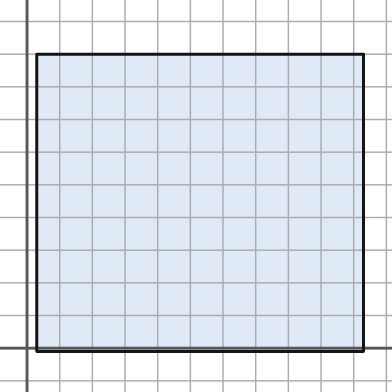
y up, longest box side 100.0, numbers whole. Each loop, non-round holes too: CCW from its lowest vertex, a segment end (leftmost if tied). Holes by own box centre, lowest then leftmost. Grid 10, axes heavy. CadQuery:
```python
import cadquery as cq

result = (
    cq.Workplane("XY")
    .moveTo(3.0, -1.0)
    .lineTo(103.0, -1.0)
    .lineTo(103.0, 90.0)
    .lineTo(3.0, 90.0)
    .close()
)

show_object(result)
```